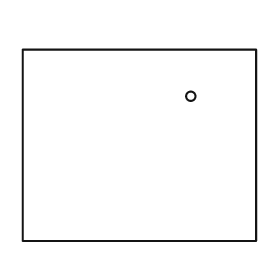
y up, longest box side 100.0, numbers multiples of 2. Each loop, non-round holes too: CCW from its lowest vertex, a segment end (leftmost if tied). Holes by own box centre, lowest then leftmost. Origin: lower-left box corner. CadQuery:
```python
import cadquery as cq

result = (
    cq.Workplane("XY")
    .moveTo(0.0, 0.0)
    .lineTo(100.0, 0.0)
    .lineTo(100.0, 82.0)
    .lineTo(0.0, 82.0)
    .close()
    .moveTo(72.0, 62.0)
    .circle(2.0)
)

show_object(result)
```